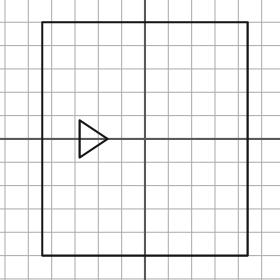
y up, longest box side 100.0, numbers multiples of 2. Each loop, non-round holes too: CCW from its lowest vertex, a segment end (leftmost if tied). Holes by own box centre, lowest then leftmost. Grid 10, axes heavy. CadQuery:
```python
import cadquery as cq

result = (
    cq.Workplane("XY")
    .moveTo(-44.0, -50.0)
    .lineTo(44.0, -50.0)
    .lineTo(44.0, 50.0)
    .lineTo(-44.0, 50.0)
    .close()
    .moveTo(-28.0, -8.0)
    .lineTo(-16.0, 0.0)
    .lineTo(-28.0, 8.0)
    .close()
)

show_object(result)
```